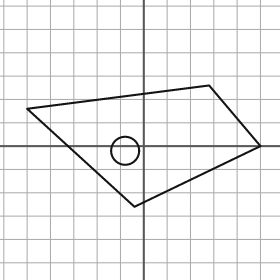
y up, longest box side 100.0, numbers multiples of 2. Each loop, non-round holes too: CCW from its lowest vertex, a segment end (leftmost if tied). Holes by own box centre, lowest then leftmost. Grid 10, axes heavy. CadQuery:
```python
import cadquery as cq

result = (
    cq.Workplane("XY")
    .moveTo(-4.0, -26.0)
    .lineTo(50.0, 0.0)
    .lineTo(28.0, 26.0)
    .lineTo(-50.0, 16.0)
    .close()
    .moveTo(-8.0, -2.0)
    .circle(6.0)
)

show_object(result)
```